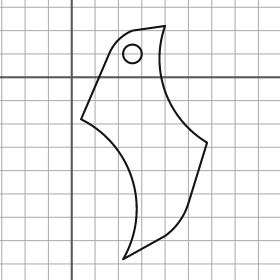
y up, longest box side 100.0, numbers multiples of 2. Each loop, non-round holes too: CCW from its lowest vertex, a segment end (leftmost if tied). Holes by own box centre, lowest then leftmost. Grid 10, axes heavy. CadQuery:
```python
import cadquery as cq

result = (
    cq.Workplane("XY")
    .moveTo(22.0, -78.0)
    .lineTo(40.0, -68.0)
    .threePointArc((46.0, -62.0), (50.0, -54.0))
    .lineTo(58.0, -28.0)
    .threePointArc((40.0, -6.0), (40.0, 22.0))
    .lineTo(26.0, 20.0)
    .threePointArc((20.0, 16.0), (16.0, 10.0))
    .lineTo(4.0, -18.0)
    .threePointArc((26.0, -44.0), (22.0, -78.0))
    .close()
    .moveTo(26.0, 10.0)
    .circle(4.0)
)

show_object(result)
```